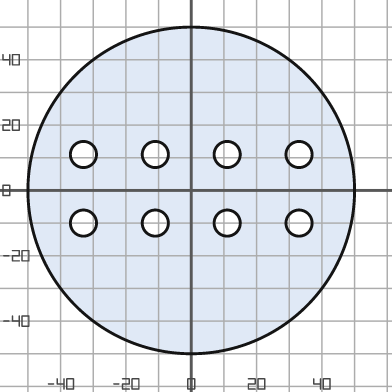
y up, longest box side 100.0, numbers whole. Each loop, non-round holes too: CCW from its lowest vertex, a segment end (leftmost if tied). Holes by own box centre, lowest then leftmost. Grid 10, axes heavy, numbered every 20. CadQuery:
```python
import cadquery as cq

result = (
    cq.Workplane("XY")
    .moveTo(0.0, 0.0)
    .circle(50.0)
    .moveTo(-33.0, -10.0)
    .circle(4.0)
    .moveTo(-11.0, -10.0)
    .circle(4.0)
    .moveTo(11.0, -10.0)
    .circle(4.0)
    .moveTo(33.0, -10.0)
    .circle(4.0)
    .moveTo(-33.0, 11.0)
    .circle(4.0)
    .moveTo(-11.0, 11.0)
    .circle(4.0)
    .moveTo(11.0, 11.0)
    .circle(4.0)
    .moveTo(33.0, 11.0)
    .circle(4.0)
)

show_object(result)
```